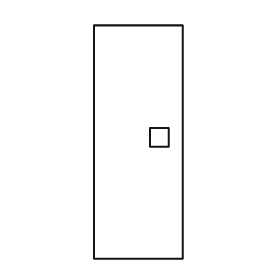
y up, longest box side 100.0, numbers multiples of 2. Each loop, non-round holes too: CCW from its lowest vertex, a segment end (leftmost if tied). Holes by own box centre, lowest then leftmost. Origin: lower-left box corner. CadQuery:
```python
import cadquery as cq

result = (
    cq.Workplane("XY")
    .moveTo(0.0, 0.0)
    .lineTo(38.0, 0.0)
    .lineTo(38.0, 100.0)
    .lineTo(0.0, 100.0)
    .close()
    .moveTo(24.0, 48.0)
    .lineTo(32.0, 48.0)
    .lineTo(32.0, 56.0)
    .lineTo(24.0, 56.0)
    .close()
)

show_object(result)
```